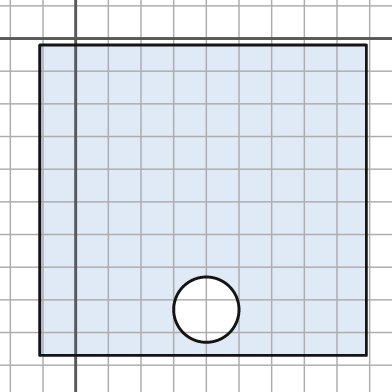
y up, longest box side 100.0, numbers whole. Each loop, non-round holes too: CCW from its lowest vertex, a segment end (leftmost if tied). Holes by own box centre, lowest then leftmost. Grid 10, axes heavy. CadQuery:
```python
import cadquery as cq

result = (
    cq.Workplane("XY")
    .moveTo(-11.0, -97.0)
    .lineTo(89.0, -97.0)
    .lineTo(89.0, -2.0)
    .lineTo(-11.0, -2.0)
    .close()
    .moveTo(40.0, -83.0)
    .circle(10.0)
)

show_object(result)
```